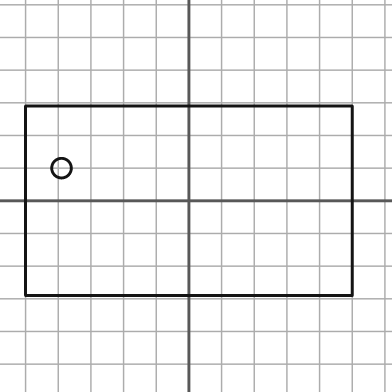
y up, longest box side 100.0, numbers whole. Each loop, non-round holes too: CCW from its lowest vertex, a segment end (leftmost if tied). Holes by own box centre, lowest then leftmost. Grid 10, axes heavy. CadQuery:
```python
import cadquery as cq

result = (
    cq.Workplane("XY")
    .moveTo(-50.0, -29.0)
    .lineTo(50.0, -29.0)
    .lineTo(50.0, 29.0)
    .lineTo(-50.0, 29.0)
    .close()
    .moveTo(-39.0, 10.0)
    .circle(3.0)
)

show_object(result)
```